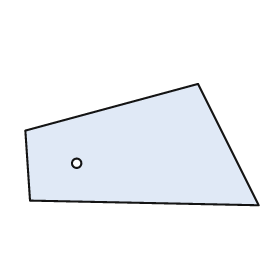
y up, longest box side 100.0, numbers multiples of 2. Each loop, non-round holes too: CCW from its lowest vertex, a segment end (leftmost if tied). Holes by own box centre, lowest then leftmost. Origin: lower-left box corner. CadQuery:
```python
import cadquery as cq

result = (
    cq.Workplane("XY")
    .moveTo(100.0, 0.0)
    .lineTo(74.0, 52.0)
    .lineTo(0.0, 32.0)
    .lineTo(2.0, 2.0)
    .close()
    .moveTo(22.0, 18.0)
    .circle(2.0)
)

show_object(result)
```